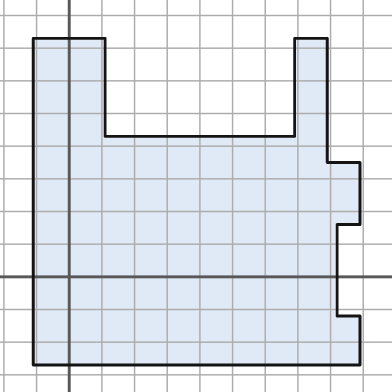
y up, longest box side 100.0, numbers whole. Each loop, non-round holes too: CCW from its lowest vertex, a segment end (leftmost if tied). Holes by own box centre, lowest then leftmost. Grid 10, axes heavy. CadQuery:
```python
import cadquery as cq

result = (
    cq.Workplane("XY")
    .moveTo(-11.0, -27.0)
    .lineTo(89.0, -27.0)
    .lineTo(89.0, -12.0)
    .lineTo(82.0, -12.0)
    .lineTo(82.0, 16.0)
    .lineTo(89.0, 16.0)
    .lineTo(89.0, 35.0)
    .lineTo(79.0, 35.0)
    .lineTo(79.0, 73.0)
    .lineTo(69.0, 73.0)
    .lineTo(69.0, 43.0)
    .lineTo(11.0, 43.0)
    .lineTo(11.0, 73.0)
    .lineTo(-11.0, 73.0)
    .close()
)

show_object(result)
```